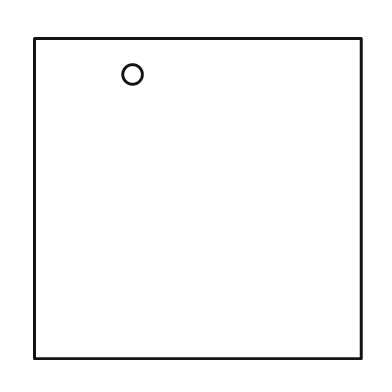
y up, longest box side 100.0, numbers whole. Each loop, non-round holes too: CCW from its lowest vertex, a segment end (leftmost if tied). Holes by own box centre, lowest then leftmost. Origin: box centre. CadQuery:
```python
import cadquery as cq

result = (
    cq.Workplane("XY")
    .moveTo(-50.0, -49.0)
    .lineTo(50.0, -49.0)
    .lineTo(50.0, 49.0)
    .lineTo(-50.0, 49.0)
    .close()
    .moveTo(-20.0, 38.0)
    .circle(3.0)
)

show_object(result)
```